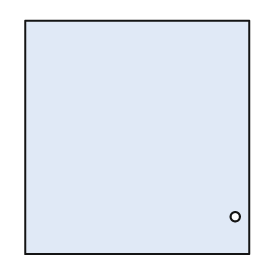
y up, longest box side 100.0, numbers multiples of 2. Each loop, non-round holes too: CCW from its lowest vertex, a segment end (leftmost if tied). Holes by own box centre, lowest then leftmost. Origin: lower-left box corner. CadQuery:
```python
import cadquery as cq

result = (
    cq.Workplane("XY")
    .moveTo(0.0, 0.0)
    .lineTo(96.0, 0.0)
    .lineTo(96.0, 100.0)
    .lineTo(0.0, 100.0)
    .close()
    .moveTo(90.0, 16.0)
    .circle(2.0)
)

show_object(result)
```